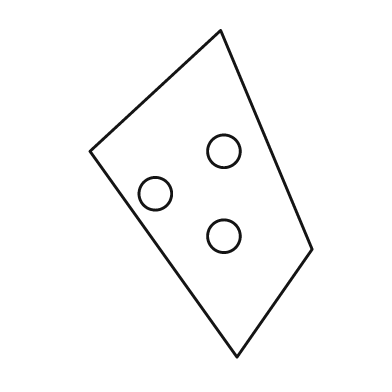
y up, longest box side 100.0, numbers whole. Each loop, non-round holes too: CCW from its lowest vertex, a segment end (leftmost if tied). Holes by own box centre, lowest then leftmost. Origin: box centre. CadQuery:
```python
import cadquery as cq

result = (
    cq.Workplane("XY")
    .moveTo(11.0, -50.0)
    .lineTo(34.0, -17.0)
    .lineTo(6.0, 50.0)
    .lineTo(-34.0, 13.0)
    .close()
    .moveTo(7.0, -13.0)
    .circle(5.0)
    .moveTo(-14.0, 0.0)
    .circle(5.0)
    .moveTo(7.0, 13.0)
    .circle(5.0)
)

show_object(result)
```